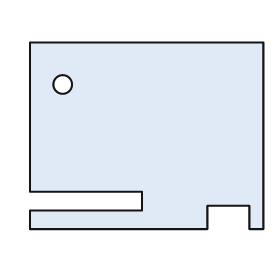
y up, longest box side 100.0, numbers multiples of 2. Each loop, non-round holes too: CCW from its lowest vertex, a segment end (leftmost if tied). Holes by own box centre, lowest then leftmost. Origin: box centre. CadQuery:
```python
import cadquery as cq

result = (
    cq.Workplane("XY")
    .moveTo(-50.0, -40.0)
    .lineTo(26.0, -40.0)
    .lineTo(26.0, -30.0)
    .lineTo(44.0, -30.0)
    .lineTo(44.0, -40.0)
    .lineTo(50.0, -40.0)
    .lineTo(50.0, 40.0)
    .lineTo(-50.0, 40.0)
    .lineTo(-50.0, -24.0)
    .lineTo(-2.0, -24.0)
    .lineTo(-2.0, -32.0)
    .lineTo(-50.0, -32.0)
    .close()
    .moveTo(-36.0, 22.0)
    .circle(4.0)
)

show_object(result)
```